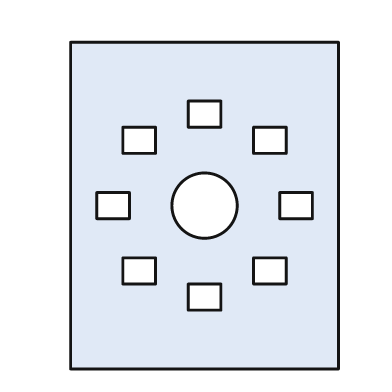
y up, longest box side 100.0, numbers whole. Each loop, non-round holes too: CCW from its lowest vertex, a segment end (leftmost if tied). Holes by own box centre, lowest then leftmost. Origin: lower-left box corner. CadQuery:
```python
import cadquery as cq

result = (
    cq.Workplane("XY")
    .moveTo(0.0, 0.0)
    .lineTo(82.0, 0.0)
    .lineTo(82.0, 100.0)
    .lineTo(0.0, 100.0)
    .close()
    .moveTo(36.0, 18.0)
    .lineTo(46.0, 18.0)
    .lineTo(46.0, 26.0)
    .lineTo(36.0, 26.0)
    .close()
    .moveTo(16.0, 26.0)
    .lineTo(26.0, 26.0)
    .lineTo(26.0, 34.0)
    .lineTo(16.0, 34.0)
    .close()
    .moveTo(56.0, 26.0)
    .lineTo(66.0, 26.0)
    .lineTo(66.0, 34.0)
    .lineTo(56.0, 34.0)
    .close()
    .moveTo(8.0, 46.0)
    .lineTo(18.0, 46.0)
    .lineTo(18.0, 54.0)
    .lineTo(8.0, 54.0)
    .close()
    .moveTo(41.0, 50.0)
    .circle(10.0)
    .moveTo(64.0, 46.0)
    .lineTo(74.0, 46.0)
    .lineTo(74.0, 54.0)
    .lineTo(64.0, 54.0)
    .close()
    .moveTo(16.0, 66.0)
    .lineTo(26.0, 66.0)
    .lineTo(26.0, 74.0)
    .lineTo(16.0, 74.0)
    .close()
    .moveTo(56.0, 66.0)
    .lineTo(66.0, 66.0)
    .lineTo(66.0, 74.0)
    .lineTo(56.0, 74.0)
    .close()
    .moveTo(36.0, 74.0)
    .lineTo(46.0, 74.0)
    .lineTo(46.0, 82.0)
    .lineTo(36.0, 82.0)
    .close()
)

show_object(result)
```